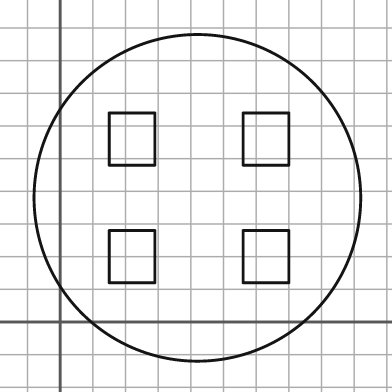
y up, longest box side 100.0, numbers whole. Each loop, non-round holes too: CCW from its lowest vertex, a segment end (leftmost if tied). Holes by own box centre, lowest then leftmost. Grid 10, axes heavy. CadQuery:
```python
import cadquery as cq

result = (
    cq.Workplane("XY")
    .moveTo(42.0, 38.0)
    .circle(50.0)
    .moveTo(15.0, 12.0)
    .lineTo(29.0, 12.0)
    .lineTo(29.0, 28.0)
    .lineTo(15.0, 28.0)
    .close()
    .moveTo(56.0, 12.0)
    .lineTo(70.0, 12.0)
    .lineTo(70.0, 28.0)
    .lineTo(56.0, 28.0)
    .close()
    .moveTo(15.0, 48.0)
    .lineTo(29.0, 48.0)
    .lineTo(29.0, 64.0)
    .lineTo(15.0, 64.0)
    .close()
    .moveTo(56.0, 48.0)
    .lineTo(70.0, 48.0)
    .lineTo(70.0, 64.0)
    .lineTo(56.0, 64.0)
    .close()
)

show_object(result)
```